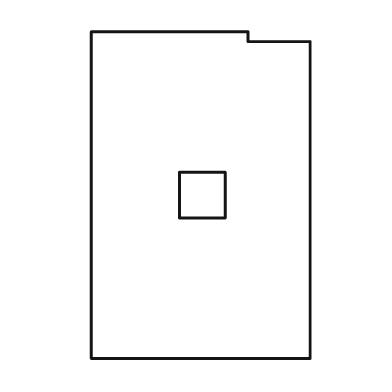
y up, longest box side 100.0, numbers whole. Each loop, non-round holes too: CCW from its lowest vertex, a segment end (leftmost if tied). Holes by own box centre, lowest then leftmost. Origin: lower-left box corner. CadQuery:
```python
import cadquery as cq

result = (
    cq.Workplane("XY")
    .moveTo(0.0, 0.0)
    .lineTo(67.0, 0.0)
    .lineTo(67.0, 97.0)
    .lineTo(48.0, 97.0)
    .lineTo(48.0, 100.0)
    .lineTo(0.0, 100.0)
    .close()
    .moveTo(27.0, 43.0)
    .lineTo(41.0, 43.0)
    .lineTo(41.0, 57.0)
    .lineTo(27.0, 57.0)
    .close()
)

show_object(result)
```